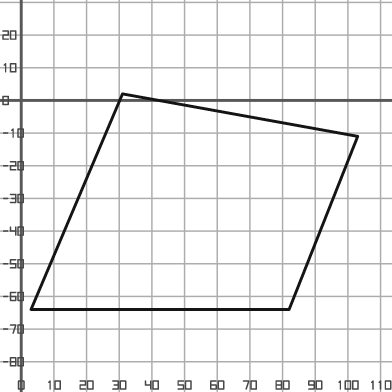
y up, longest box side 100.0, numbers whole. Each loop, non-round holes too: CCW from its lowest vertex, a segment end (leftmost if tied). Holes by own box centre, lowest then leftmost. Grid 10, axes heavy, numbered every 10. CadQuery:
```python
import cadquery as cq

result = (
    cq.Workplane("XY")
    .moveTo(3.0, -64.0)
    .lineTo(82.0, -64.0)
    .lineTo(103.0, -11.0)
    .lineTo(31.0, 2.0)
    .close()
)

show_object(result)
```